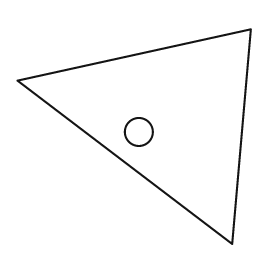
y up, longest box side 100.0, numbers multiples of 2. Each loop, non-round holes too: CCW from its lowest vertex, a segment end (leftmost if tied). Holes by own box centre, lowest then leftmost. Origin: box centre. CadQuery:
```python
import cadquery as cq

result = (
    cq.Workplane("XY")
    .moveTo(42.0, -46.0)
    .lineTo(50.0, 46.0)
    .lineTo(-50.0, 24.0)
    .close()
    .moveTo(2.0, 2.0)
    .circle(6.0)
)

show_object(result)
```